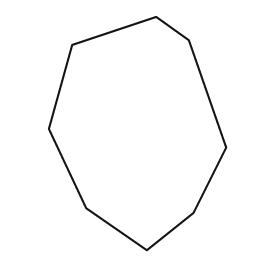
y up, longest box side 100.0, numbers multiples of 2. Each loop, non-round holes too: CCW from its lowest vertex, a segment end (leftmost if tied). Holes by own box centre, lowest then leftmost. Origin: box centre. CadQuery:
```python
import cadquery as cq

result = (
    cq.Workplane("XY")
    .moveTo(4.0, -50.0)
    .lineTo(24.0, -34.0)
    .lineTo(38.0, -6.0)
    .lineTo(22.0, 40.0)
    .lineTo(8.0, 50.0)
    .lineTo(-28.0, 38.0)
    .lineTo(-38.0, 2.0)
    .lineTo(-22.0, -32.0)
    .close()
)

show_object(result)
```